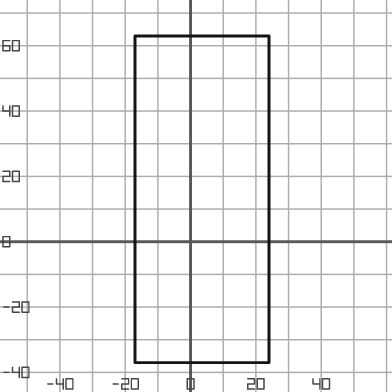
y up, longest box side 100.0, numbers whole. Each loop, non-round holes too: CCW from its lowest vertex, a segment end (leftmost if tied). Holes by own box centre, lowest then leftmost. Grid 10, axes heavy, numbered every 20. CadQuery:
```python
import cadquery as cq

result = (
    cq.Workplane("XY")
    .moveTo(-17.0, -37.0)
    .lineTo(24.0, -37.0)
    .lineTo(24.0, 63.0)
    .lineTo(-17.0, 63.0)
    .close()
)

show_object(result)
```